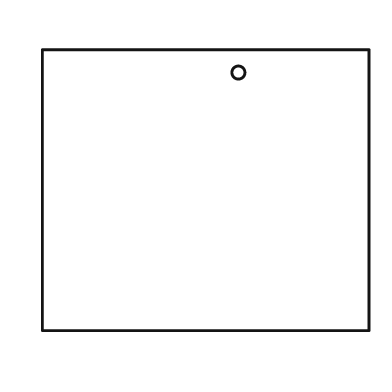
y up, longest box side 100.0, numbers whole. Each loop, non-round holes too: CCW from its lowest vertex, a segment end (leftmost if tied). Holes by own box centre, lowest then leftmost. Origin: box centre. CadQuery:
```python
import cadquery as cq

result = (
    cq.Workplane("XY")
    .moveTo(-50.0, -43.0)
    .lineTo(50.0, -43.0)
    .lineTo(50.0, 43.0)
    .lineTo(-50.0, 43.0)
    .close()
    .moveTo(10.0, 36.0)
    .circle(2.0)
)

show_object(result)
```